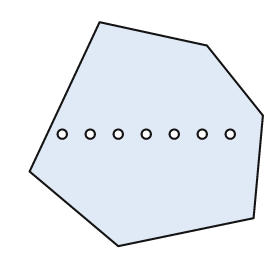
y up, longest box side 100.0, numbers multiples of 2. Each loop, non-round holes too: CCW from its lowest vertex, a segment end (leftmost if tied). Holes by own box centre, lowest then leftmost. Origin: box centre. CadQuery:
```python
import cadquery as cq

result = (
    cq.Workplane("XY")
    .moveTo(-12.0, -48.0)
    .lineTo(46.0, -36.0)
    .lineTo(50.0, 8.0)
    .lineTo(26.0, 38.0)
    .lineTo(-20.0, 48.0)
    .lineTo(-50.0, -16.0)
    .close()
    .moveTo(-36.0, 0.0)
    .circle(2.0)
    .moveTo(-24.0, 0.0)
    .circle(2.0)
    .moveTo(-12.0, 0.0)
    .circle(2.0)
    .moveTo(0.0, 0.0)
    .circle(2.0)
    .moveTo(12.0, 0.0)
    .circle(2.0)
    .moveTo(24.0, 0.0)
    .circle(2.0)
    .moveTo(36.0, 0.0)
    .circle(2.0)
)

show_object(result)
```